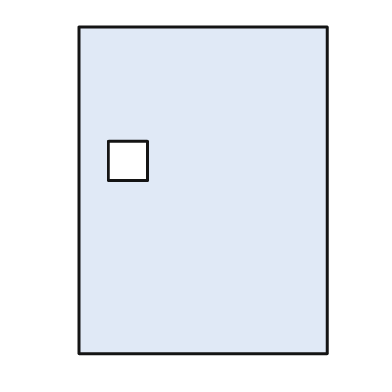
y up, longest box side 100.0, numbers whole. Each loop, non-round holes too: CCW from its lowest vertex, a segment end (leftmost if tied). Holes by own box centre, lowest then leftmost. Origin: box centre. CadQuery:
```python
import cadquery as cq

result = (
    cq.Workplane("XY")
    .moveTo(-38.0, -50.0)
    .lineTo(38.0, -50.0)
    .lineTo(38.0, 50.0)
    .lineTo(-38.0, 50.0)
    .close()
    .moveTo(-29.0, 3.0)
    .lineTo(-17.0, 3.0)
    .lineTo(-17.0, 15.0)
    .lineTo(-29.0, 15.0)
    .close()
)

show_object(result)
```